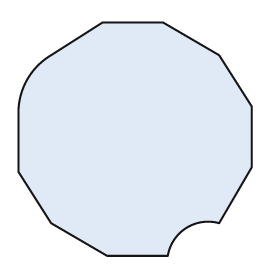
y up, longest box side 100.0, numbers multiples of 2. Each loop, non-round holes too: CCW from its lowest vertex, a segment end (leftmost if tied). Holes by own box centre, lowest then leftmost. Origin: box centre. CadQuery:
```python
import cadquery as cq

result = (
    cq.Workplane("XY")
    .moveTo(-12.0, -50.0)
    .lineTo(14.0, -50.0)
    .threePointArc((22.0, -38.0), (36.0, -36.0))
    .lineTo(50.0, -12.0)
    .lineTo(50.0, 14.0)
    .lineTo(36.0, 36.0)
    .lineTo(12.0, 50.0)
    .lineTo(-14.0, 50.0)
    .lineTo(-36.0, 36.0)
    .threePointArc((-46.0, 26.0), (-50.0, 12.0))
    .lineTo(-50.0, -14.0)
    .lineTo(-36.0, -36.0)
    .close()
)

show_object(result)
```